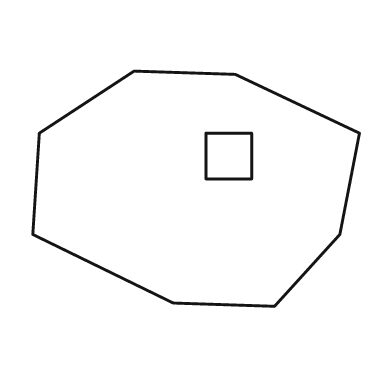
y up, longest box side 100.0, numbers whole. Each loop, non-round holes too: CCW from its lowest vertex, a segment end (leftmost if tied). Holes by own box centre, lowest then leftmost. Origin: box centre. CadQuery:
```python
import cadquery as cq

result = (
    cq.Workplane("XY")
    .moveTo(24.0, -36.0)
    .lineTo(44.0, -14.0)
    .lineTo(50.0, 17.0)
    .lineTo(12.0, 35.0)
    .lineTo(-19.0, 36.0)
    .lineTo(-48.0, 17.0)
    .lineTo(-50.0, -14.0)
    .lineTo(-7.0, -35.0)
    .close()
    .moveTo(3.0, 3.0)
    .lineTo(17.0, 3.0)
    .lineTo(17.0, 17.0)
    .lineTo(3.0, 17.0)
    .close()
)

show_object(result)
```